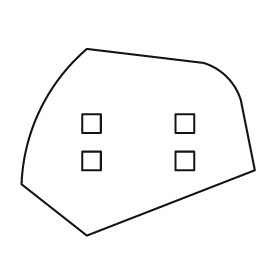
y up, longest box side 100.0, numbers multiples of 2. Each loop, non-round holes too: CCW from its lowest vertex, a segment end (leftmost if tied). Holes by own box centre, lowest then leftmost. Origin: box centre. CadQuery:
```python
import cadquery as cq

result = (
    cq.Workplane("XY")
    .moveTo(-22.0, -40.0)
    .lineTo(50.0, -12.0)
    .lineTo(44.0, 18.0)
    .threePointArc((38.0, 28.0), (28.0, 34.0))
    .lineTo(-22.0, 40.0)
    .threePointArc((-42.0, 14.0), (-50.0, -18.0))
    .close()
    .moveTo(-24.0, -12.0)
    .lineTo(-16.0, -12.0)
    .lineTo(-16.0, -4.0)
    .lineTo(-24.0, -4.0)
    .close()
    .moveTo(16.0, -12.0)
    .lineTo(24.0, -12.0)
    .lineTo(24.0, -4.0)
    .lineTo(16.0, -4.0)
    .close()
    .moveTo(-24.0, 4.0)
    .lineTo(-16.0, 4.0)
    .lineTo(-16.0, 12.0)
    .lineTo(-24.0, 12.0)
    .close()
    .moveTo(16.0, 4.0)
    .lineTo(24.0, 4.0)
    .lineTo(24.0, 12.0)
    .lineTo(16.0, 12.0)
    .close()
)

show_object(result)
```